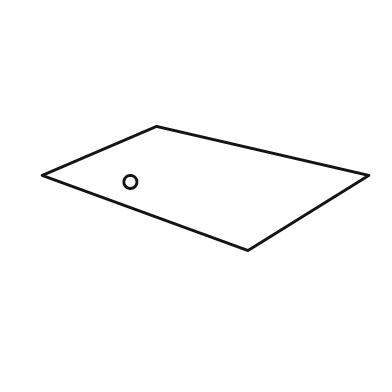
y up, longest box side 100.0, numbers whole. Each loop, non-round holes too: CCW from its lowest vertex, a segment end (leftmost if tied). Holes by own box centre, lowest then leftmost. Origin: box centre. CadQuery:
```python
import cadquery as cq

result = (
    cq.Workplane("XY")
    .moveTo(13.0, -19.0)
    .lineTo(50.0, 4.0)
    .lineTo(-15.0, 19.0)
    .lineTo(-50.0, 4.0)
    .close()
    .moveTo(-23.0, 2.0)
    .circle(2.0)
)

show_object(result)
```